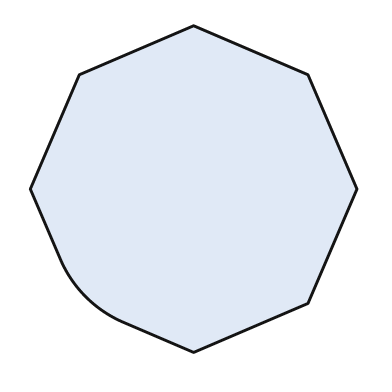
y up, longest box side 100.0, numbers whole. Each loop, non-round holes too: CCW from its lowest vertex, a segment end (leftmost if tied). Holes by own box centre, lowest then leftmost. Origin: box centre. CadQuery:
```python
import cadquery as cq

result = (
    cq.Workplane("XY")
    .moveTo(0.0, -50.0)
    .lineTo(35.0, -35.0)
    .lineTo(50.0, 0.0)
    .lineTo(35.0, 35.0)
    .lineTo(0.0, 50.0)
    .lineTo(-35.0, 35.0)
    .lineTo(-50.0, 0.0)
    .lineTo(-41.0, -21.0)
    .threePointArc((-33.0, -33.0), (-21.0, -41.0))
    .close()
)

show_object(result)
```